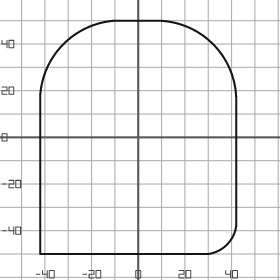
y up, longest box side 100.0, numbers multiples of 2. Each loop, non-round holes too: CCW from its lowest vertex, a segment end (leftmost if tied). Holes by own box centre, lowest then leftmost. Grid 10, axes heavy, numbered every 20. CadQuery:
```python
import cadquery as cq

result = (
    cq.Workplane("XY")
    .moveTo(-42.0, -50.0)
    .lineTo(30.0, -50.0)
    .threePointArc((38.0, -46.0), (42.0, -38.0))
    .lineTo(42.0, 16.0)
    .threePointArc((32.0, 40.0), (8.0, 50.0))
    .lineTo(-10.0, 50.0)
    .threePointArc((-32.0, 40.0), (-42.0, 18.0))
    .close()
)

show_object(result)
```